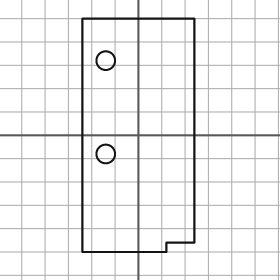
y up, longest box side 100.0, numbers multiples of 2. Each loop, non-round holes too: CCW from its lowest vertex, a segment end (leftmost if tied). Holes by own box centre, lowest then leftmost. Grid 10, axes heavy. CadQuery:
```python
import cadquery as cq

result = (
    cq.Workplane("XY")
    .moveTo(-24.0, -50.0)
    .lineTo(12.0, -50.0)
    .lineTo(12.0, -46.0)
    .lineTo(24.0, -46.0)
    .lineTo(24.0, 50.0)
    .lineTo(-24.0, 50.0)
    .close()
    .moveTo(-14.0, -8.0)
    .circle(4.0)
    .moveTo(-14.0, 32.0)
    .circle(4.0)
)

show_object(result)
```